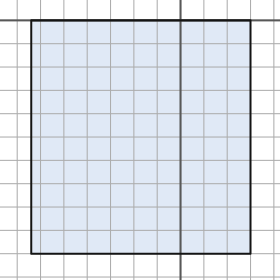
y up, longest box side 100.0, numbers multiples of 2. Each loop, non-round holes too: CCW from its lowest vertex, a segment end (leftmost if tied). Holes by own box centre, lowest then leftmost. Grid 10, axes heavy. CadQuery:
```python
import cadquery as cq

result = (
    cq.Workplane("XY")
    .moveTo(-64.0, -100.0)
    .lineTo(30.0, -100.0)
    .lineTo(30.0, 0.0)
    .lineTo(-64.0, 0.0)
    .close()
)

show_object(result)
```